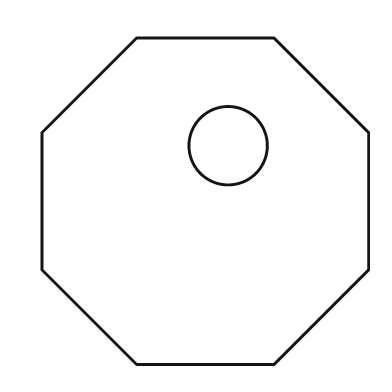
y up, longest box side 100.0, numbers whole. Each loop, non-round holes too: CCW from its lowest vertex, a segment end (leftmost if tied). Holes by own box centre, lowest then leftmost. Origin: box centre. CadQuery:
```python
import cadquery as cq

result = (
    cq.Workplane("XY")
    .moveTo(-21.0, -50.0)
    .lineTo(21.0, -50.0)
    .lineTo(50.0, -21.0)
    .lineTo(50.0, 21.0)
    .lineTo(21.0, 50.0)
    .lineTo(-21.0, 50.0)
    .lineTo(-50.0, 21.0)
    .lineTo(-50.0, -21.0)
    .close()
    .moveTo(7.0, 17.0)
    .circle(12.0)
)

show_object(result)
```